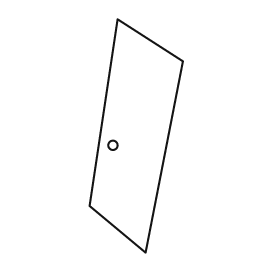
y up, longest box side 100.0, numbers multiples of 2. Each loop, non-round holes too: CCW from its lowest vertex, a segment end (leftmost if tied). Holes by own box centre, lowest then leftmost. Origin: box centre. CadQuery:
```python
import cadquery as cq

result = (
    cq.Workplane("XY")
    .moveTo(4.0, -50.0)
    .lineTo(20.0, 32.0)
    .lineTo(-8.0, 50.0)
    .lineTo(-20.0, -30.0)
    .close()
    .moveTo(-10.0, -4.0)
    .circle(2.0)
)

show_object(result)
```